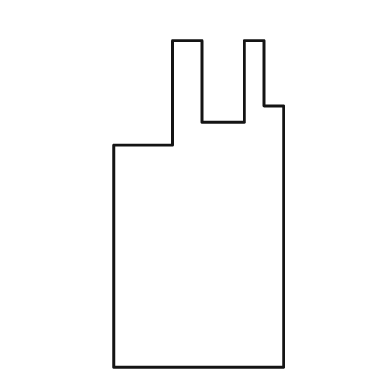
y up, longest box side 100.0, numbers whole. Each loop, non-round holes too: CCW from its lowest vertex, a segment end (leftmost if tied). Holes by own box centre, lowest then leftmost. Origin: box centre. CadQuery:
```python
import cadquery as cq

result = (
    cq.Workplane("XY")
    .moveTo(-26.0, -50.0)
    .lineTo(26.0, -50.0)
    .lineTo(26.0, 30.0)
    .lineTo(20.0, 30.0)
    .lineTo(20.0, 50.0)
    .lineTo(14.0, 50.0)
    .lineTo(14.0, 25.0)
    .lineTo(1.0, 25.0)
    .lineTo(1.0, 50.0)
    .lineTo(-8.0, 50.0)
    .lineTo(-8.0, 18.0)
    .lineTo(-26.0, 18.0)
    .close()
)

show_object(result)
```